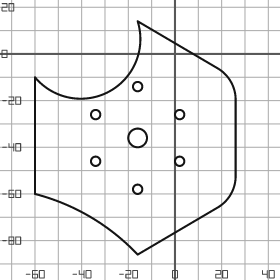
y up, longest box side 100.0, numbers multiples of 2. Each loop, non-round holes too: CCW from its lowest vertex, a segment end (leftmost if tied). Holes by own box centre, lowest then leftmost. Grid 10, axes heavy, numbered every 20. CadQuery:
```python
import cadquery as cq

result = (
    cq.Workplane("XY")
    .moveTo(-16.0, -86.0)
    .lineTo(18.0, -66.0)
    .threePointArc((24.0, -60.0), (26.0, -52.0))
    .lineTo(26.0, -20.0)
    .threePointArc((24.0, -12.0), (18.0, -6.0))
    .lineTo(-16.0, 14.0)
    .threePointArc((-28.0, -16.0), (-60.0, -10.0))
    .lineTo(-60.0, -60.0)
    .threePointArc((-36.0, -70.0), (-16.0, -86.0))
    .close()
    .moveTo(-16.0, -58.0)
    .circle(2.0)
    .moveTo(-34.0, -46.0)
    .circle(2.0)
    .moveTo(2.0, -46.0)
    .circle(2.0)
    .moveTo(-16.0, -36.0)
    .circle(4.0)
    .moveTo(-34.0, -26.0)
    .circle(2.0)
    .moveTo(2.0, -26.0)
    .circle(2.0)
    .moveTo(-16.0, -14.0)
    .circle(2.0)
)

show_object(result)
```